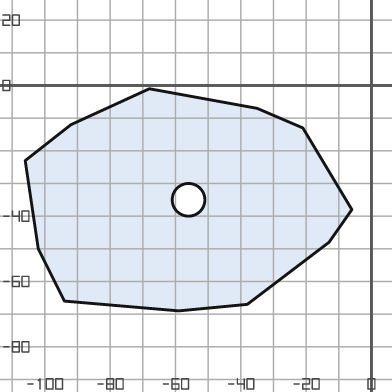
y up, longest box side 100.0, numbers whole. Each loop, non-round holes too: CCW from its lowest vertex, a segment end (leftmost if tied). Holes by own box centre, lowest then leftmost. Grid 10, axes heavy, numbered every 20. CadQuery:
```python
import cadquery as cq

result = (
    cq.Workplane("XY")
    .moveTo(-59.0, -69.0)
    .lineTo(-38.0, -67.0)
    .lineTo(-13.0, -48.0)
    .lineTo(-6.0, -38.0)
    .lineTo(-21.0, -13.0)
    .lineTo(-35.0, -7.0)
    .lineTo(-68.0, -1.0)
    .lineTo(-92.0, -12.0)
    .lineTo(-106.0, -23.0)
    .lineTo(-102.0, -50.0)
    .lineTo(-94.0, -66.0)
    .close()
    .moveTo(-56.0, -35.0)
    .circle(5.0)
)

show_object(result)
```